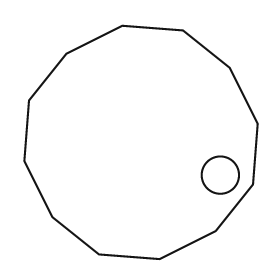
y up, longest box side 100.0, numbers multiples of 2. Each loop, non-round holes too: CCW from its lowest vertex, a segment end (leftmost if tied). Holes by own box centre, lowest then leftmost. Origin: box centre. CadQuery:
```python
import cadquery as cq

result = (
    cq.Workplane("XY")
    .moveTo(8.0, -50.0)
    .lineTo(32.0, -38.0)
    .lineTo(48.0, -18.0)
    .lineTo(50.0, 8.0)
    .lineTo(38.0, 32.0)
    .lineTo(18.0, 48.0)
    .lineTo(-8.0, 50.0)
    .lineTo(-32.0, 38.0)
    .lineTo(-48.0, 18.0)
    .lineTo(-50.0, -8.0)
    .lineTo(-38.0, -32.0)
    .lineTo(-18.0, -48.0)
    .close()
    .moveTo(34.0, -14.0)
    .circle(8.0)
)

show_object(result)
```